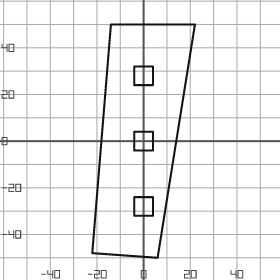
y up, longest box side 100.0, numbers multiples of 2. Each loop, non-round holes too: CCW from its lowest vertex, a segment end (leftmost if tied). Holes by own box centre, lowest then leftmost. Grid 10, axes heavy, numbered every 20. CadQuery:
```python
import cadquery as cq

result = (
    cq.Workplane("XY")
    .moveTo(6.0, -50.0)
    .lineTo(22.0, 50.0)
    .lineTo(-14.0, 50.0)
    .lineTo(-22.0, -48.0)
    .close()
    .moveTo(-4.0, -32.0)
    .lineTo(4.0, -32.0)
    .lineTo(4.0, -24.0)
    .lineTo(-4.0, -24.0)
    .close()
    .moveTo(-4.0, -4.0)
    .lineTo(4.0, -4.0)
    .lineTo(4.0, 4.0)
    .lineTo(-4.0, 4.0)
    .close()
    .moveTo(-4.0, 24.0)
    .lineTo(4.0, 24.0)
    .lineTo(4.0, 32.0)
    .lineTo(-4.0, 32.0)
    .close()
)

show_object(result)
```